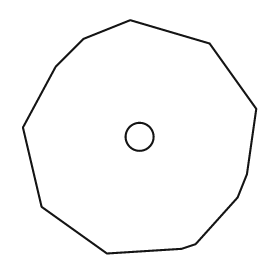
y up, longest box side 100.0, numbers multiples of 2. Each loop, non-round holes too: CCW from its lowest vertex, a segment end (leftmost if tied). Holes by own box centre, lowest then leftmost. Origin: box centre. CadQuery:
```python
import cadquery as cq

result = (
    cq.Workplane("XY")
    .moveTo(-14.0, -50.0)
    .lineTo(18.0, -48.0)
    .lineTo(24.0, -46.0)
    .lineTo(42.0, -26.0)
    .lineTo(46.0, -16.0)
    .lineTo(50.0, 12.0)
    .lineTo(30.0, 40.0)
    .lineTo(-4.0, 50.0)
    .lineTo(-24.0, 42.0)
    .lineTo(-36.0, 30.0)
    .lineTo(-50.0, 4.0)
    .lineTo(-42.0, -30.0)
    .close()
    .moveTo(0.0, 0.0)
    .circle(6.0)
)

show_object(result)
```